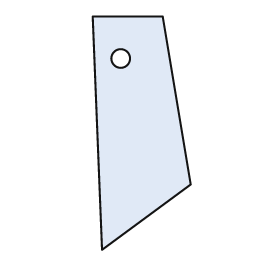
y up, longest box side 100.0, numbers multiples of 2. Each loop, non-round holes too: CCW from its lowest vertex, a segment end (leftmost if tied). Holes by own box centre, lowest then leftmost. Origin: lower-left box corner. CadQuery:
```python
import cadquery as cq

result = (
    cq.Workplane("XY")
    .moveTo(4.0, 0.0)
    .lineTo(42.0, 28.0)
    .lineTo(30.0, 100.0)
    .lineTo(0.0, 100.0)
    .close()
    .moveTo(12.0, 82.0)
    .circle(4.0)
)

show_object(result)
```